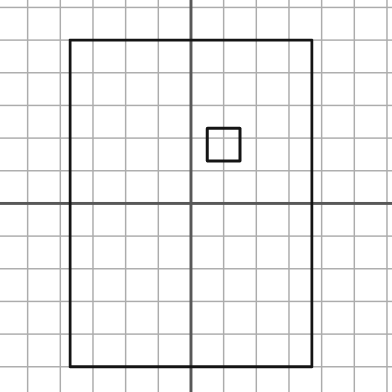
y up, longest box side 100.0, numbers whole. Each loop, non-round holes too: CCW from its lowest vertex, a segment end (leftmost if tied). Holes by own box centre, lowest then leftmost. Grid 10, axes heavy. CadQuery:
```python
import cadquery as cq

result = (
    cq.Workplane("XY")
    .moveTo(-37.0, -50.0)
    .lineTo(37.0, -50.0)
    .lineTo(37.0, 50.0)
    .lineTo(-37.0, 50.0)
    .close()
    .moveTo(5.0, 13.0)
    .lineTo(15.0, 13.0)
    .lineTo(15.0, 23.0)
    .lineTo(5.0, 23.0)
    .close()
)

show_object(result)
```